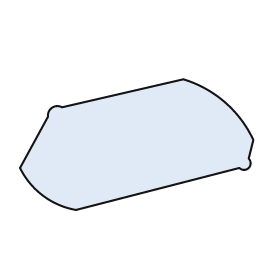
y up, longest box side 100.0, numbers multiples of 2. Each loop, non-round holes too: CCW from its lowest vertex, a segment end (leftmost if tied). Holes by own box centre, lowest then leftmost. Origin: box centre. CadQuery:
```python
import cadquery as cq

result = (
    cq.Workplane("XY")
    .moveTo(-26.0, -28.0)
    .lineTo(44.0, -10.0)
    .threePointArc((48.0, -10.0), (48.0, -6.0))
    .lineTo(50.0, 2.0)
    .threePointArc((38.0, 18.0), (20.0, 28.0))
    .lineTo(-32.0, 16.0)
    .threePointArc((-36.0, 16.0), (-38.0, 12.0))
    .lineTo(-50.0, -10.0)
    .threePointArc((-40.0, -22.0), (-26.0, -28.0))
    .close()
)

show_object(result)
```